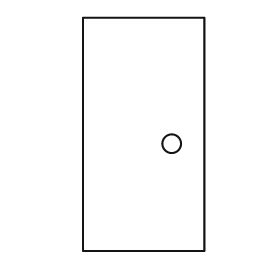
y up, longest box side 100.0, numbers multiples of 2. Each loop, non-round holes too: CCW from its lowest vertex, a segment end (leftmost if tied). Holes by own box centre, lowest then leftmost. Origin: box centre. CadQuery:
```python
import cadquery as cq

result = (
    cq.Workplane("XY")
    .moveTo(-26.0, -50.0)
    .lineTo(26.0, -50.0)
    .lineTo(26.0, 50.0)
    .lineTo(-26.0, 50.0)
    .close()
    .moveTo(12.0, -4.0)
    .circle(4.0)
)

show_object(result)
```